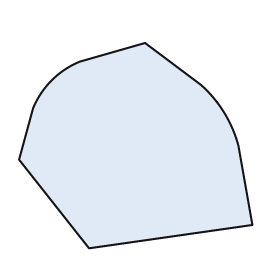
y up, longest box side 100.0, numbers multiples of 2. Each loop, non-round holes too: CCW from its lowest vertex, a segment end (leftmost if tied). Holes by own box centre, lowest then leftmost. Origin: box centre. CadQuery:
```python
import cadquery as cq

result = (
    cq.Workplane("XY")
    .moveTo(-20.0, -44.0)
    .lineTo(50.0, -34.0)
    .lineTo(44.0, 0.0)
    .threePointArc((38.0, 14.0), (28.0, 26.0))
    .lineTo(4.0, 44.0)
    .lineTo(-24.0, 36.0)
    .threePointArc((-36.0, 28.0), (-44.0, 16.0))
    .lineTo(-50.0, -6.0)
    .close()
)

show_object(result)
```